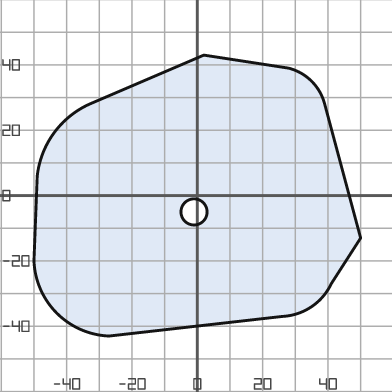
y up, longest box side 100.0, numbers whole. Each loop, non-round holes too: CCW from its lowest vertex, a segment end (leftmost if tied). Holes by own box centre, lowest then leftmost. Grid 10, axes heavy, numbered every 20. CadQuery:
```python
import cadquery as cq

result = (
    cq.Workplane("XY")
    .moveTo(-27.0, -43.0)
    .lineTo(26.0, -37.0)
    .threePointArc((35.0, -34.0), (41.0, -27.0))
    .lineTo(50.0, -13.0)
    .lineTo(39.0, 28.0)
    .threePointArc((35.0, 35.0), (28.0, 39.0))
    .lineTo(2.0, 43.0)
    .lineTo(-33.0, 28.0)
    .threePointArc((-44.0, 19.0), (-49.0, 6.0))
    .lineTo(-50.0, -20.0)
    .threePointArc((-43.0, -36.0), (-27.0, -43.0))
    .close()
    .moveTo(-1.0, -5.0)
    .circle(4.0)
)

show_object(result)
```